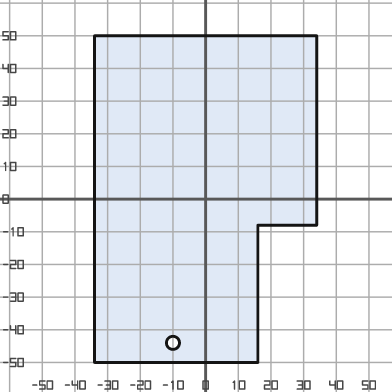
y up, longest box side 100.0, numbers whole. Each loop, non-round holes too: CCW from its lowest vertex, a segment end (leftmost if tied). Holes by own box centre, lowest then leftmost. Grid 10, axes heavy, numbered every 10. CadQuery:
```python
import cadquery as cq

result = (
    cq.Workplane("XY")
    .moveTo(-34.0, -50.0)
    .lineTo(16.0, -50.0)
    .lineTo(16.0, -8.0)
    .lineTo(34.0, -8.0)
    .lineTo(34.0, 50.0)
    .lineTo(-34.0, 50.0)
    .close()
    .moveTo(-10.0, -44.0)
    .circle(2.0)
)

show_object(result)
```